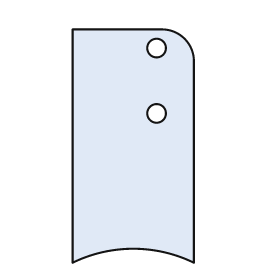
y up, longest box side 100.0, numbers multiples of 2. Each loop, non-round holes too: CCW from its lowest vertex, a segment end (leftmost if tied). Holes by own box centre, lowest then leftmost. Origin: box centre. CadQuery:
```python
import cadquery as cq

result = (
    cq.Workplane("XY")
    .moveTo(-26.0, -50.0)
    .threePointArc((0.0, -44.0), (26.0, -50.0))
    .lineTo(26.0, 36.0)
    .threePointArc((22.0, 46.0), (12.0, 50.0))
    .lineTo(-26.0, 50.0)
    .close()
    .moveTo(10.0, 14.0)
    .circle(4.0)
    .moveTo(10.0, 42.0)
    .circle(4.0)
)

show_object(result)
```